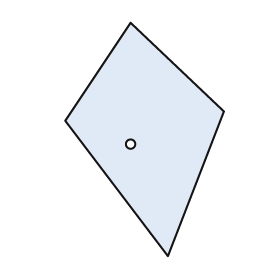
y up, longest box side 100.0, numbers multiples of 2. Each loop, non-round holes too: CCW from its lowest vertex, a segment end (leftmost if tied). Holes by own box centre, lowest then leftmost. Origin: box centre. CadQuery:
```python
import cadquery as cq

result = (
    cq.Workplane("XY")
    .moveTo(10.0, -50.0)
    .lineTo(34.0, 12.0)
    .lineTo(-6.0, 50.0)
    .lineTo(-34.0, 8.0)
    .close()
    .moveTo(-6.0, -2.0)
    .circle(2.0)
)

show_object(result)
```